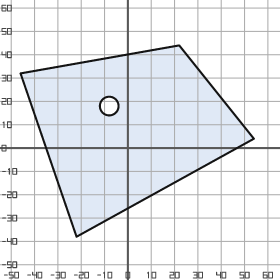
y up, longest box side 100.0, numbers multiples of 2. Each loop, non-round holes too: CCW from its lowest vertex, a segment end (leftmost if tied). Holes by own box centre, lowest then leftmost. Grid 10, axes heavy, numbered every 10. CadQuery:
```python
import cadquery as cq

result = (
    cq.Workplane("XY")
    .moveTo(-22.0, -38.0)
    .lineTo(54.0, 4.0)
    .lineTo(22.0, 44.0)
    .lineTo(-46.0, 32.0)
    .close()
    .moveTo(-8.0, 18.0)
    .circle(4.0)
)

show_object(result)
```